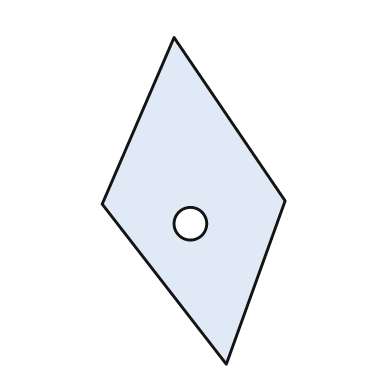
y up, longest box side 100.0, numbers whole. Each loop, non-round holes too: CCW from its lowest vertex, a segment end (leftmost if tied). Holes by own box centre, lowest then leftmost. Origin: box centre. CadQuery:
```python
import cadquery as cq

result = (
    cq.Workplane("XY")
    .moveTo(10.0, -50.0)
    .lineTo(28.0, 0.0)
    .lineTo(-6.0, 50.0)
    .lineTo(-28.0, -1.0)
    .close()
    .moveTo(-1.0, -7.0)
    .circle(5.0)
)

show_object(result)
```